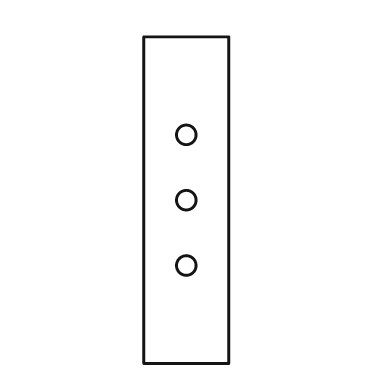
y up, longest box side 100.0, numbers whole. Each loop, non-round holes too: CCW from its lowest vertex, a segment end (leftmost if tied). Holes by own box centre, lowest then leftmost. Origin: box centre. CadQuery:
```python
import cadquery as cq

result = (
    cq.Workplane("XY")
    .moveTo(-13.0, -50.0)
    .lineTo(13.0, -50.0)
    .lineTo(13.0, 50.0)
    .lineTo(-13.0, 50.0)
    .close()
    .moveTo(0.0, -20.0)
    .circle(3.0)
    .moveTo(0.0, 0.0)
    .circle(3.0)
    .moveTo(0.0, 20.0)
    .circle(3.0)
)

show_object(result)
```